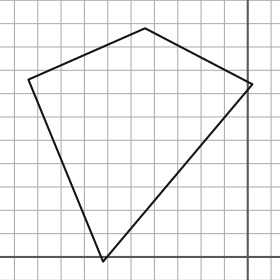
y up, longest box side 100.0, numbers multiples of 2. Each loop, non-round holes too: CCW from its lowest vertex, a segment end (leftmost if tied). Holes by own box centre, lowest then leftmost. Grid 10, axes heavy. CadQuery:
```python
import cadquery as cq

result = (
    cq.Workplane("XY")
    .moveTo(-62.0, -2.0)
    .lineTo(2.0, 74.0)
    .lineTo(-44.0, 98.0)
    .lineTo(-94.0, 76.0)
    .close()
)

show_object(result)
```